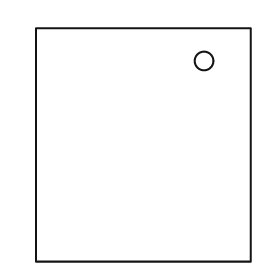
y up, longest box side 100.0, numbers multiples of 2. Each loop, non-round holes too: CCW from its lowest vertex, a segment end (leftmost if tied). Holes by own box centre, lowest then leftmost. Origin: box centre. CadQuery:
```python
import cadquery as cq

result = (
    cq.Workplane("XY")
    .moveTo(-46.0, -50.0)
    .lineTo(46.0, -50.0)
    .lineTo(46.0, 50.0)
    .lineTo(-46.0, 50.0)
    .close()
    .moveTo(26.0, 36.0)
    .circle(4.0)
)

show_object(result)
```